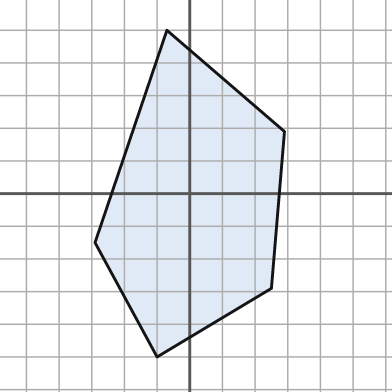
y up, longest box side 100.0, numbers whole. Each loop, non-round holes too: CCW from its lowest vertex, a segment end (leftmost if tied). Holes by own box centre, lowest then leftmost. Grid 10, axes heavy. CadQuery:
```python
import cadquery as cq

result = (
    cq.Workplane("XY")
    .moveTo(-10.0, -50.0)
    .lineTo(25.0, -29.0)
    .lineTo(29.0, 19.0)
    .lineTo(-7.0, 50.0)
    .lineTo(-29.0, -15.0)
    .close()
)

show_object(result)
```